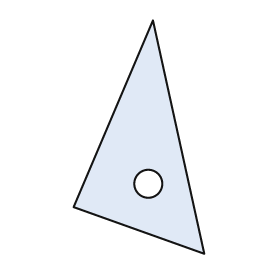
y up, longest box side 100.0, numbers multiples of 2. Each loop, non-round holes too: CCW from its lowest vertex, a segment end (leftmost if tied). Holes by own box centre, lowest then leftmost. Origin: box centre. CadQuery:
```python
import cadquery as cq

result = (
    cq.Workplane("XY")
    .moveTo(28.0, -50.0)
    .lineTo(6.0, 50.0)
    .lineTo(-28.0, -30.0)
    .close()
    .moveTo(4.0, -20.0)
    .circle(6.0)
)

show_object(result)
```